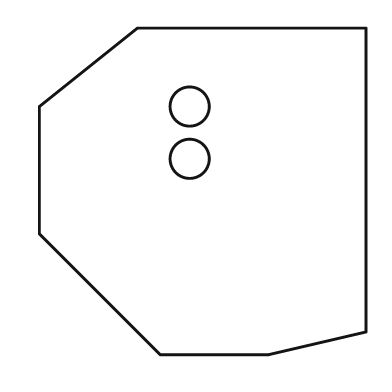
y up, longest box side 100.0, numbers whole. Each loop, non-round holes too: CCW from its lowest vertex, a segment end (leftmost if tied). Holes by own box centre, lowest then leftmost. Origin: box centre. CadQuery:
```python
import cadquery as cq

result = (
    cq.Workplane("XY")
    .moveTo(-13.0, -50.0)
    .lineTo(20.0, -50.0)
    .lineTo(50.0, -43.0)
    .lineTo(50.0, 50.0)
    .lineTo(-20.0, 50.0)
    .lineTo(-50.0, 26.0)
    .lineTo(-50.0, -13.0)
    .close()
    .moveTo(-4.0, 10.0)
    .circle(6.0)
    .moveTo(-4.0, 26.0)
    .circle(6.0)
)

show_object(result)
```